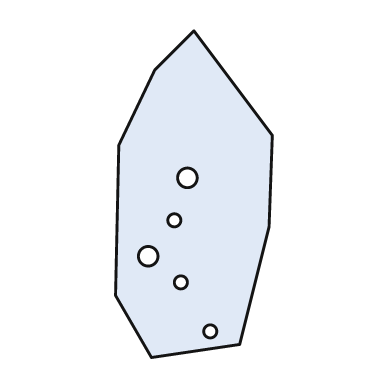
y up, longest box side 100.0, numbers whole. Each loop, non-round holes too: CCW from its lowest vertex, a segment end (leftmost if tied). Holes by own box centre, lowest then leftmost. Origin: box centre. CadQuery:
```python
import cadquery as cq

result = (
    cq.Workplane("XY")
    .moveTo(-13.0, -50.0)
    .lineTo(14.0, -46.0)
    .lineTo(23.0, -10.0)
    .lineTo(24.0, 18.0)
    .lineTo(0.0, 50.0)
    .lineTo(-12.0, 38.0)
    .lineTo(-23.0, 15.0)
    .lineTo(-24.0, -31.0)
    .close()
    .moveTo(5.0, -42.0)
    .circle(2.0)
    .moveTo(-4.0, -27.0)
    .circle(2.0)
    .moveTo(-14.0, -19.0)
    .circle(3.0)
    .moveTo(-6.0, -8.0)
    .circle(2.0)
    .moveTo(-2.0, 5.0)
    .circle(3.0)
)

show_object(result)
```